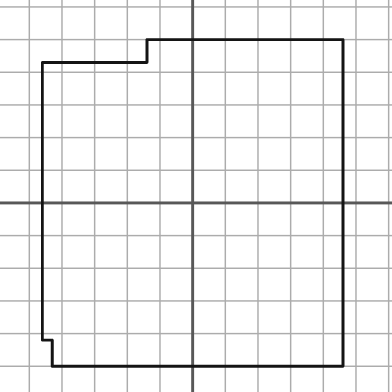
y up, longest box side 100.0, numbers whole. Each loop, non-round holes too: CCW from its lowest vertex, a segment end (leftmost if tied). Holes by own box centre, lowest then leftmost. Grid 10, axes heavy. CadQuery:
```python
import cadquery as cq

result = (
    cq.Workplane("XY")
    .moveTo(-43.0, -50.0)
    .lineTo(46.0, -50.0)
    .lineTo(46.0, 50.0)
    .lineTo(-14.0, 50.0)
    .lineTo(-14.0, 43.0)
    .lineTo(-46.0, 43.0)
    .lineTo(-46.0, -42.0)
    .lineTo(-43.0, -42.0)
    .close()
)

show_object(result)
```